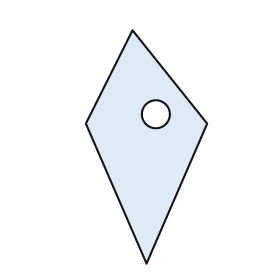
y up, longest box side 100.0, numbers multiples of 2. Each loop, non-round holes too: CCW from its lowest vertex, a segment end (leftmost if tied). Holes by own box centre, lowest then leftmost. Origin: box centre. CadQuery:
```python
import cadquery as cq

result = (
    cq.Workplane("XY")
    .moveTo(0.0, -50.0)
    .lineTo(26.0, 10.0)
    .lineTo(-6.0, 50.0)
    .lineTo(-26.0, 10.0)
    .close()
    .moveTo(4.0, 14.0)
    .circle(6.0)
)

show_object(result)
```